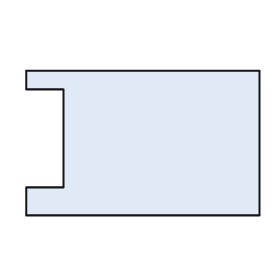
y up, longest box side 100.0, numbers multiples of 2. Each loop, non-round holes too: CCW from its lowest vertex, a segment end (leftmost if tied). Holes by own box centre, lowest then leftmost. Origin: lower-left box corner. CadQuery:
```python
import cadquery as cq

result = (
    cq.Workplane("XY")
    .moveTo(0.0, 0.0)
    .lineTo(100.0, 0.0)
    .lineTo(100.0, 62.0)
    .lineTo(0.0, 62.0)
    .lineTo(0.0, 54.0)
    .lineTo(16.0, 54.0)
    .lineTo(16.0, 12.0)
    .lineTo(0.0, 12.0)
    .close()
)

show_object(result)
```